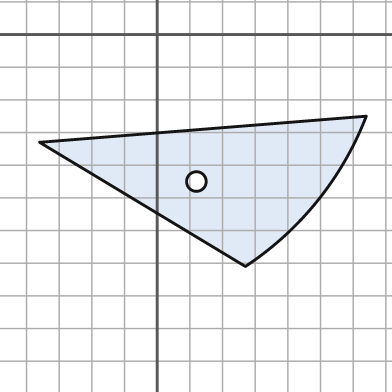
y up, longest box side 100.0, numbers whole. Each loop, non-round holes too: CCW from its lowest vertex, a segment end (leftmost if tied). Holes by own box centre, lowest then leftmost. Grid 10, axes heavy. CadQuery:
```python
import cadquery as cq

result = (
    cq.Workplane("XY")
    .moveTo(27.0, -71.0)
    .threePointArc((49.0, -51.0), (64.0, -25.0))
    .lineTo(-36.0, -33.0)
    .close()
    .moveTo(12.0, -45.0)
    .circle(3.0)
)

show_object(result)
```